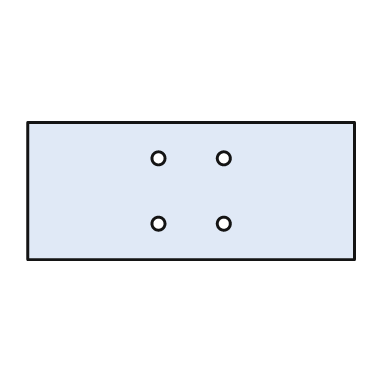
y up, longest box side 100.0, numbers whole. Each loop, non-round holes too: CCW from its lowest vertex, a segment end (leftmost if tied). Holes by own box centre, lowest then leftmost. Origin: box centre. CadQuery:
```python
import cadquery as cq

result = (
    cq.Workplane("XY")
    .moveTo(-50.0, -21.0)
    .lineTo(50.0, -21.0)
    .lineTo(50.0, 21.0)
    .lineTo(-50.0, 21.0)
    .close()
    .moveTo(-10.0, -10.0)
    .circle(2.0)
    .moveTo(10.0, -10.0)
    .circle(2.0)
    .moveTo(-10.0, 10.0)
    .circle(2.0)
    .moveTo(10.0, 10.0)
    .circle(2.0)
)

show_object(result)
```